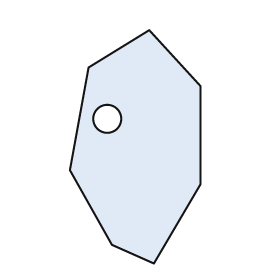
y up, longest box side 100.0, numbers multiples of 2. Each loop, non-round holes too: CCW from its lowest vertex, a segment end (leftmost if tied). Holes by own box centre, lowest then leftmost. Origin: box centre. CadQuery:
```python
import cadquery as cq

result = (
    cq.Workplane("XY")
    .moveTo(8.0, -50.0)
    .lineTo(28.0, -16.0)
    .lineTo(28.0, 26.0)
    .lineTo(6.0, 50.0)
    .lineTo(-20.0, 34.0)
    .lineTo(-28.0, -10.0)
    .lineTo(-10.0, -42.0)
    .close()
    .moveTo(-12.0, 12.0)
    .circle(6.0)
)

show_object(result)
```